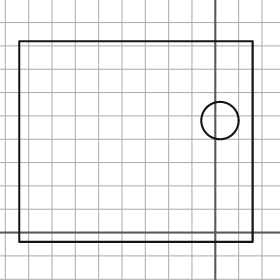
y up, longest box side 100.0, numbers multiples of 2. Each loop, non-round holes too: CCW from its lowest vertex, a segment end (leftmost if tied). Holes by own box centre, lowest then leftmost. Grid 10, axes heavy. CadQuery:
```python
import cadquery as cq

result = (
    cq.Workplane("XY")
    .moveTo(-84.0, -4.0)
    .lineTo(16.0, -4.0)
    .lineTo(16.0, 82.0)
    .lineTo(-84.0, 82.0)
    .close()
    .moveTo(2.0, 48.0)
    .circle(8.0)
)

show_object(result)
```